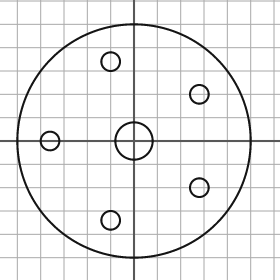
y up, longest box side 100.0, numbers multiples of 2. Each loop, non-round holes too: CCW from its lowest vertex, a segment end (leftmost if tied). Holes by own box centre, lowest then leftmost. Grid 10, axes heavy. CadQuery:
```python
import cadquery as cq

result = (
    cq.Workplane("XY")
    .moveTo(0.0, 0.0)
    .circle(50.0)
    .moveTo(-10.0, -34.0)
    .circle(4.0)
    .moveTo(28.0, -20.0)
    .circle(4.0)
    .moveTo(-36.0, 0.0)
    .circle(4.0)
    .moveTo(0.0, 0.0)
    .circle(8.0)
    .moveTo(28.0, 20.0)
    .circle(4.0)
    .moveTo(-10.0, 34.0)
    .circle(4.0)
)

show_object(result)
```